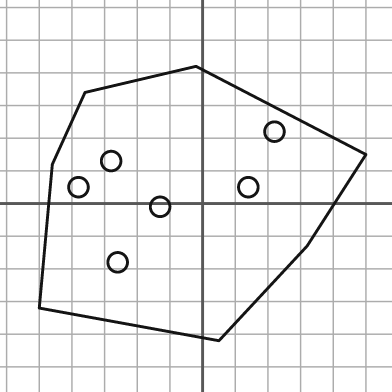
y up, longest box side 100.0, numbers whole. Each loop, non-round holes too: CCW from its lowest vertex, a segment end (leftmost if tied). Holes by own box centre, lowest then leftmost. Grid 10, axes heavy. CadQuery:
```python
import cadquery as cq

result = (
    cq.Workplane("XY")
    .moveTo(5.0, -42.0)
    .lineTo(32.0, -13.0)
    .lineTo(50.0, 15.0)
    .lineTo(-2.0, 42.0)
    .lineTo(-36.0, 34.0)
    .lineTo(-46.0, 12.0)
    .lineTo(-50.0, -32.0)
    .close()
    .moveTo(-26.0, -18.0)
    .circle(3.0)
    .moveTo(-13.0, -1.0)
    .circle(3.0)
    .moveTo(-38.0, 5.0)
    .circle(3.0)
    .moveTo(14.0, 5.0)
    .circle(3.0)
    .moveTo(-28.0, 13.0)
    .circle(3.0)
    .moveTo(22.0, 22.0)
    .circle(3.0)
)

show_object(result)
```